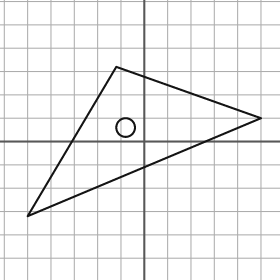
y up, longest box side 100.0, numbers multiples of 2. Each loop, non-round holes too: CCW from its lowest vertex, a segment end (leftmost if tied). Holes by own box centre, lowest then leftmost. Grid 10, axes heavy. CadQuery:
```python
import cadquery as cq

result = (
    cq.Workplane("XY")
    .moveTo(-50.0, -32.0)
    .lineTo(50.0, 10.0)
    .lineTo(-12.0, 32.0)
    .close()
    .moveTo(-8.0, 6.0)
    .circle(4.0)
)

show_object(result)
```